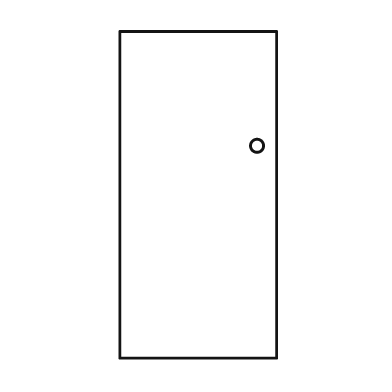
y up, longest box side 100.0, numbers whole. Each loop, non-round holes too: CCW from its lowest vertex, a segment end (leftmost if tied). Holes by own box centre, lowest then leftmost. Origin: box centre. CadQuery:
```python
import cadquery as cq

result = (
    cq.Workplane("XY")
    .moveTo(-24.0, -50.0)
    .lineTo(24.0, -50.0)
    .lineTo(24.0, 50.0)
    .lineTo(-24.0, 50.0)
    .close()
    .moveTo(18.0, 15.0)
    .circle(2.0)
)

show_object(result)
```